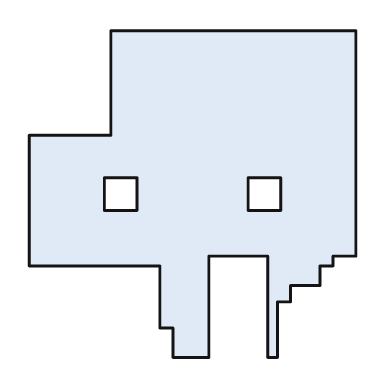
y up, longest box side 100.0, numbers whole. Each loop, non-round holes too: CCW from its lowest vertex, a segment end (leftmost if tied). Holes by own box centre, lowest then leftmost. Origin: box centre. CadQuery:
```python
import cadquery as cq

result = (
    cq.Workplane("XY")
    .moveTo(-6.0, -50.0)
    .lineTo(5.0, -50.0)
    .lineTo(5.0, -19.0)
    .lineTo(23.0, -19.0)
    .lineTo(23.0, -50.0)
    .lineTo(26.0, -50.0)
    .lineTo(26.0, -33.0)
    .lineTo(30.0, -33.0)
    .lineTo(30.0, -28.0)
    .lineTo(39.0, -28.0)
    .lineTo(39.0, -22.0)
    .lineTo(43.0, -22.0)
    .lineTo(43.0, -19.0)
    .lineTo(50.0, -19.0)
    .lineTo(50.0, 50.0)
    .lineTo(-25.0, 50.0)
    .lineTo(-25.0, 18.0)
    .lineTo(-50.0, 18.0)
    .lineTo(-50.0, -22.0)
    .lineTo(-10.0, -22.0)
    .lineTo(-10.0, -41.0)
    .lineTo(-6.0, -41.0)
    .close()
    .moveTo(-27.0, -5.0)
    .lineTo(-17.0, -5.0)
    .lineTo(-17.0, 5.0)
    .lineTo(-27.0, 5.0)
    .close()
    .moveTo(17.0, -5.0)
    .lineTo(27.0, -5.0)
    .lineTo(27.0, 5.0)
    .lineTo(17.0, 5.0)
    .close()
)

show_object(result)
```